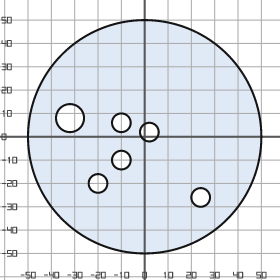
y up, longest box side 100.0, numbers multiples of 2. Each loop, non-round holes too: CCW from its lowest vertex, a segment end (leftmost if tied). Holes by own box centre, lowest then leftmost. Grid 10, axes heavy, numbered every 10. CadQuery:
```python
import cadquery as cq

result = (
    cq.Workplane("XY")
    .moveTo(0.0, 0.0)
    .circle(50.0)
    .moveTo(24.0, -26.0)
    .circle(4.0)
    .moveTo(-20.0, -20.0)
    .circle(4.0)
    .moveTo(-10.0, -10.0)
    .circle(4.0)
    .moveTo(2.0, 2.0)
    .circle(4.0)
    .moveTo(-10.0, 6.0)
    .circle(4.0)
    .moveTo(-32.0, 8.0)
    .circle(6.0)
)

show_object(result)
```